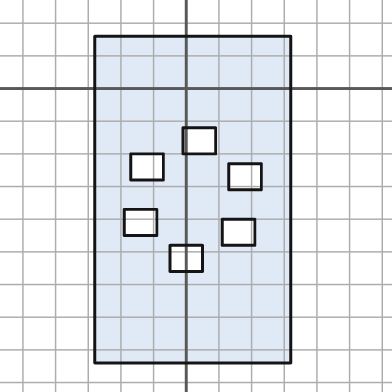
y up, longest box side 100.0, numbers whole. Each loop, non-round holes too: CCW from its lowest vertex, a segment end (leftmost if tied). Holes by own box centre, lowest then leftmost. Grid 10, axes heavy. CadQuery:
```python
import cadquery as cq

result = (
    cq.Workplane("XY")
    .moveTo(-28.0, -84.0)
    .lineTo(32.0, -84.0)
    .lineTo(32.0, 16.0)
    .lineTo(-28.0, 16.0)
    .close()
    .moveTo(-5.0, -56.0)
    .lineTo(5.0, -56.0)
    .lineTo(5.0, -48.0)
    .lineTo(-5.0, -48.0)
    .close()
    .moveTo(11.0, -48.0)
    .lineTo(21.0, -48.0)
    .lineTo(21.0, -40.0)
    .lineTo(11.0, -40.0)
    .close()
    .moveTo(-19.0, -45.0)
    .lineTo(-9.0, -45.0)
    .lineTo(-9.0, -37.0)
    .lineTo(-19.0, -37.0)
    .close()
    .moveTo(13.0, -31.0)
    .lineTo(23.0, -31.0)
    .lineTo(23.0, -23.0)
    .lineTo(13.0, -23.0)
    .close()
    .moveTo(-17.0, -28.0)
    .lineTo(-7.0, -28.0)
    .lineTo(-7.0, -20.0)
    .lineTo(-17.0, -20.0)
    .close()
    .moveTo(-1.0, -20.0)
    .lineTo(9.0, -20.0)
    .lineTo(9.0, -12.0)
    .lineTo(-1.0, -12.0)
    .close()
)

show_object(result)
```